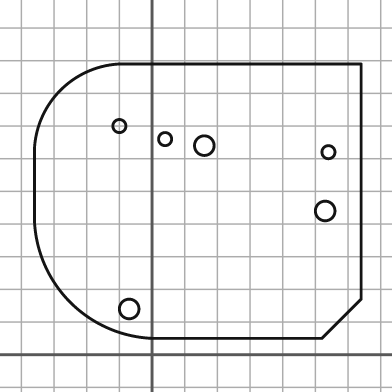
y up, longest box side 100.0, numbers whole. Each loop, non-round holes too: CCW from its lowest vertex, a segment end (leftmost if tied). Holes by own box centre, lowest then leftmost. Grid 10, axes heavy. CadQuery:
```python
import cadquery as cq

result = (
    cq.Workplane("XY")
    .moveTo(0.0, 5.0)
    .lineTo(52.0, 5.0)
    .lineTo(64.0, 17.0)
    .lineTo(64.0, 89.0)
    .lineTo(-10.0, 89.0)
    .threePointArc((-28.0, 81.0), (-36.0, 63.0))
    .lineTo(-36.0, 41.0)
    .threePointArc((-25.0, 16.0), (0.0, 5.0))
    .close()
    .moveTo(-7.0, 14.0)
    .circle(3.0)
    .moveTo(53.0, 44.0)
    .circle(3.0)
    .moveTo(54.0, 62.0)
    .circle(2.0)
    .moveTo(16.0, 64.0)
    .circle(3.0)
    .moveTo(4.0, 66.0)
    .circle(2.0)
    .moveTo(-10.0, 70.0)
    .circle(2.0)
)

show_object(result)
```